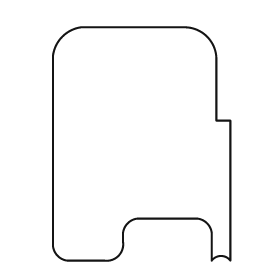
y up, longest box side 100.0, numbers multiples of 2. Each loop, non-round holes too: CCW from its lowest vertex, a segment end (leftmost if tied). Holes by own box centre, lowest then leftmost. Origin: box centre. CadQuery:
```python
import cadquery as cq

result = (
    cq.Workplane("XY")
    .moveTo(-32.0, -50.0)
    .lineTo(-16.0, -50.0)
    .threePointArc((-10.0, -48.0), (-8.0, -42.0))
    .lineTo(-8.0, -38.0)
    .threePointArc((-6.0, -34.0), (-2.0, -32.0))
    .lineTo(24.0, -32.0)
    .threePointArc((28.0, -34.0), (30.0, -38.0))
    .lineTo(30.0, -50.0)
    .threePointArc((34.0, -48.0), (38.0, -50.0))
    .lineTo(38.0, 10.0)
    .lineTo(32.0, 10.0)
    .lineTo(32.0, 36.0)
    .threePointArc((28.0, 46.0), (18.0, 50.0))
    .lineTo(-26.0, 50.0)
    .threePointArc((-34.0, 46.0), (-38.0, 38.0))
    .lineTo(-38.0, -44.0)
    .threePointArc((-36.0, -48.0), (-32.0, -50.0))
    .close()
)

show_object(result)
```